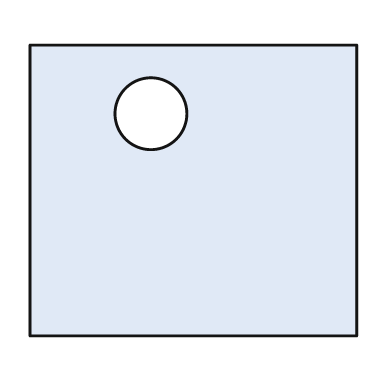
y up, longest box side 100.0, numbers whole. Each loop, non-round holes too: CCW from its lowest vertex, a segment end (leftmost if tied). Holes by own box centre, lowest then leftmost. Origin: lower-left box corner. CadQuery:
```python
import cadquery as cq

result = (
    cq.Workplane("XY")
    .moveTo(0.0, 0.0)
    .lineTo(100.0, 0.0)
    .lineTo(100.0, 89.0)
    .lineTo(0.0, 89.0)
    .close()
    .moveTo(37.0, 68.0)
    .circle(11.0)
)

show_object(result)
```